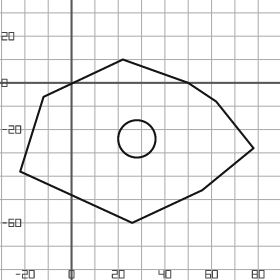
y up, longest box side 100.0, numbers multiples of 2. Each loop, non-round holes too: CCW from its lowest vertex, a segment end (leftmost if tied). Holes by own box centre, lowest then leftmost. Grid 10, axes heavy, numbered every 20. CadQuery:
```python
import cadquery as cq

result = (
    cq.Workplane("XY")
    .moveTo(26.0, -60.0)
    .lineTo(56.0, -46.0)
    .lineTo(78.0, -28.0)
    .lineTo(62.0, -8.0)
    .lineTo(50.0, 0.0)
    .lineTo(22.0, 10.0)
    .lineTo(-12.0, -6.0)
    .lineTo(-22.0, -38.0)
    .close()
    .moveTo(28.0, -24.0)
    .circle(8.0)
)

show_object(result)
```